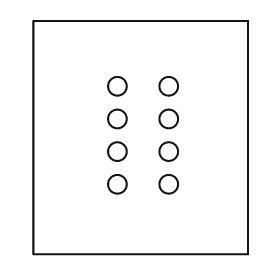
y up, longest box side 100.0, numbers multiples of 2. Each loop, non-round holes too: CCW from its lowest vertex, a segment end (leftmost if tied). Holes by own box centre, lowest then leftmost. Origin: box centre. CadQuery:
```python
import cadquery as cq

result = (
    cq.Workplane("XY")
    .moveTo(-46.0, -50.0)
    .lineTo(46.0, -50.0)
    .lineTo(46.0, 50.0)
    .lineTo(-46.0, 50.0)
    .close()
    .moveTo(-10.0, -20.0)
    .circle(4.0)
    .moveTo(12.0, -20.0)
    .circle(4.0)
    .moveTo(-10.0, -6.0)
    .circle(4.0)
    .moveTo(12.0, -6.0)
    .circle(4.0)
    .moveTo(-10.0, 8.0)
    .circle(4.0)
    .moveTo(12.0, 8.0)
    .circle(4.0)
    .moveTo(-10.0, 22.0)
    .circle(4.0)
    .moveTo(12.0, 22.0)
    .circle(4.0)
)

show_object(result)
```